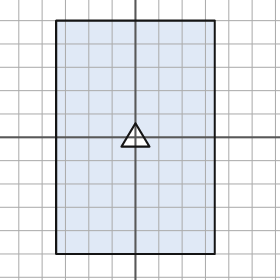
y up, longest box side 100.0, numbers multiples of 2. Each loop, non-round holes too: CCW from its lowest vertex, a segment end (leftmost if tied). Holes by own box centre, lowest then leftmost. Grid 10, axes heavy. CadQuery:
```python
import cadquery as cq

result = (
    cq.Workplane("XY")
    .moveTo(-34.0, -50.0)
    .lineTo(34.0, -50.0)
    .lineTo(34.0, 50.0)
    .lineTo(-34.0, 50.0)
    .close()
    .moveTo(-6.0, -4.0)
    .lineTo(6.0, -4.0)
    .lineTo(0.0, 6.0)
    .close()
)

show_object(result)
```